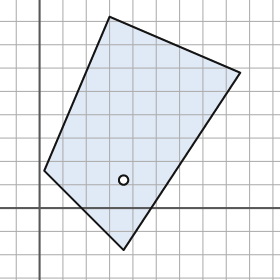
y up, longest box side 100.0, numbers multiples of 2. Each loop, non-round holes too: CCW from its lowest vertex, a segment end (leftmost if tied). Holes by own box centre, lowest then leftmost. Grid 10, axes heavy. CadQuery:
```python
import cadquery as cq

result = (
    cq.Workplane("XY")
    .moveTo(36.0, -18.0)
    .lineTo(86.0, 58.0)
    .lineTo(30.0, 82.0)
    .lineTo(2.0, 16.0)
    .close()
    .moveTo(36.0, 12.0)
    .circle(2.0)
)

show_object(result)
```